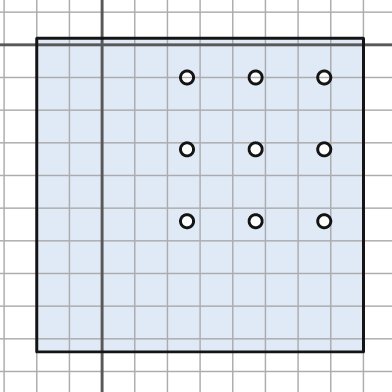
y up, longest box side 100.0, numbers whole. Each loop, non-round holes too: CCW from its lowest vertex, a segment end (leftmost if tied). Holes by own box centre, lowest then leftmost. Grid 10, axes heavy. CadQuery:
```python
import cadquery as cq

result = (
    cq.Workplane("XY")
    .moveTo(-20.0, -94.0)
    .lineTo(80.0, -94.0)
    .lineTo(80.0, 2.0)
    .lineTo(-20.0, 2.0)
    .close()
    .moveTo(26.0, -54.0)
    .circle(2.0)
    .moveTo(47.0, -54.0)
    .circle(2.0)
    .moveTo(68.0, -54.0)
    .circle(2.0)
    .moveTo(26.0, -32.0)
    .circle(2.0)
    .moveTo(47.0, -32.0)
    .circle(2.0)
    .moveTo(68.0, -32.0)
    .circle(2.0)
    .moveTo(26.0, -10.0)
    .circle(2.0)
    .moveTo(47.0, -10.0)
    .circle(2.0)
    .moveTo(68.0, -10.0)
    .circle(2.0)
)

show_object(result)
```